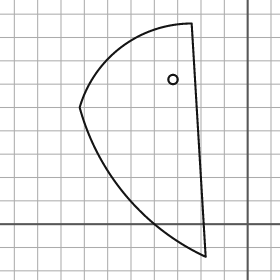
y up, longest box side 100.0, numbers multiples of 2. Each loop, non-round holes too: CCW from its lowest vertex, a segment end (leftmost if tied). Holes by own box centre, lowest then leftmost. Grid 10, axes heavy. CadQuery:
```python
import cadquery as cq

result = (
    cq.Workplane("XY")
    .moveTo(-18.0, -14.0)
    .lineTo(-24.0, 86.0)
    .threePointArc((-54.0, 76.0), (-72.0, 50.0))
    .threePointArc((-52.0, 12.0), (-18.0, -14.0))
    .close()
    .moveTo(-32.0, 62.0)
    .circle(2.0)
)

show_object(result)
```